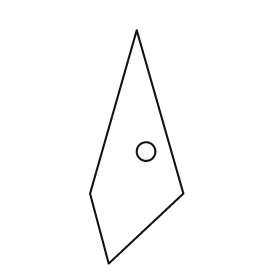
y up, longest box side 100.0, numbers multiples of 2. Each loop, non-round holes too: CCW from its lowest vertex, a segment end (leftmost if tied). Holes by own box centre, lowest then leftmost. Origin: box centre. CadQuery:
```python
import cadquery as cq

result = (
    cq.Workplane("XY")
    .moveTo(-12.0, -50.0)
    .lineTo(20.0, -20.0)
    .lineTo(0.0, 50.0)
    .lineTo(-20.0, -20.0)
    .close()
    .moveTo(4.0, -2.0)
    .circle(4.0)
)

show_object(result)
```